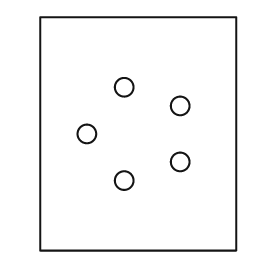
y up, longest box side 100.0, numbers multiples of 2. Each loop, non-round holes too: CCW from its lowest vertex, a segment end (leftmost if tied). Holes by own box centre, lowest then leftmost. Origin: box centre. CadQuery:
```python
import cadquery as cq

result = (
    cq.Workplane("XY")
    .moveTo(-42.0, -50.0)
    .lineTo(42.0, -50.0)
    .lineTo(42.0, 50.0)
    .lineTo(-42.0, 50.0)
    .close()
    .moveTo(-6.0, -20.0)
    .circle(4.0)
    .moveTo(18.0, -12.0)
    .circle(4.0)
    .moveTo(-22.0, 0.0)
    .circle(4.0)
    .moveTo(18.0, 12.0)
    .circle(4.0)
    .moveTo(-6.0, 20.0)
    .circle(4.0)
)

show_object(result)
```